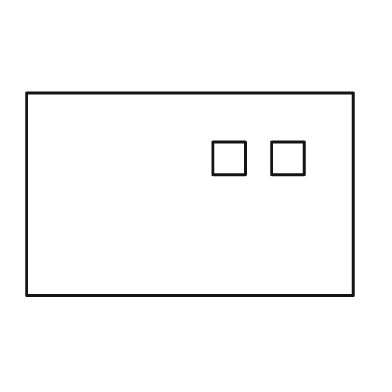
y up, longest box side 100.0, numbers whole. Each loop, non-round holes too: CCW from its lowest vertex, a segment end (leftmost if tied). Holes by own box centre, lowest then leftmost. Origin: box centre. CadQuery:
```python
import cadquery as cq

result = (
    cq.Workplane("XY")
    .moveTo(-50.0, -31.0)
    .lineTo(50.0, -31.0)
    .lineTo(50.0, 31.0)
    .lineTo(-50.0, 31.0)
    .close()
    .moveTo(7.0, 6.0)
    .lineTo(17.0, 6.0)
    .lineTo(17.0, 16.0)
    .lineTo(7.0, 16.0)
    .close()
    .moveTo(25.0, 6.0)
    .lineTo(35.0, 6.0)
    .lineTo(35.0, 16.0)
    .lineTo(25.0, 16.0)
    .close()
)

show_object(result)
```